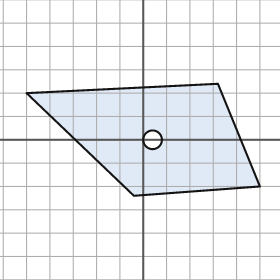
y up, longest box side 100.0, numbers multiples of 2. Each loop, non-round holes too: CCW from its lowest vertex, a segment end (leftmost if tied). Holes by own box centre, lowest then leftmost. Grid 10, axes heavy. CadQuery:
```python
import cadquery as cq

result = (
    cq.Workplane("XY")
    .moveTo(-4.0, -24.0)
    .lineTo(50.0, -20.0)
    .lineTo(32.0, 24.0)
    .lineTo(-50.0, 20.0)
    .close()
    .moveTo(4.0, 0.0)
    .circle(4.0)
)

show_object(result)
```